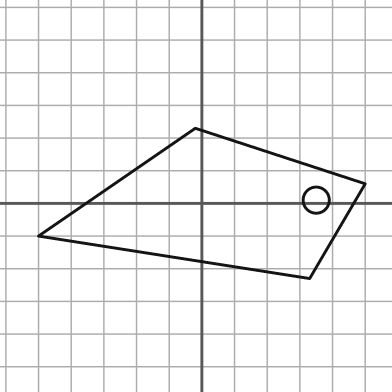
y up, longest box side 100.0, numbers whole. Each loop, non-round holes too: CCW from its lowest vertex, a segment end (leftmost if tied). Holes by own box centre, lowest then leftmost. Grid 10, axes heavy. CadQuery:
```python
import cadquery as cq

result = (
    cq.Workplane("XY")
    .moveTo(33.0, -23.0)
    .lineTo(50.0, 6.0)
    .lineTo(-2.0, 23.0)
    .lineTo(-50.0, -10.0)
    .close()
    .moveTo(35.0, 1.0)
    .circle(4.0)
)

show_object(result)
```